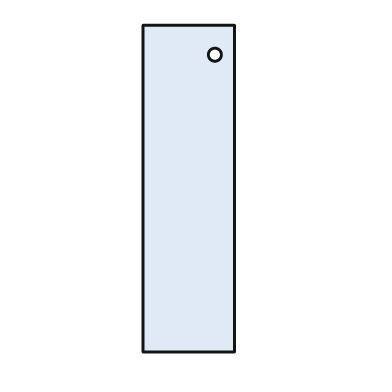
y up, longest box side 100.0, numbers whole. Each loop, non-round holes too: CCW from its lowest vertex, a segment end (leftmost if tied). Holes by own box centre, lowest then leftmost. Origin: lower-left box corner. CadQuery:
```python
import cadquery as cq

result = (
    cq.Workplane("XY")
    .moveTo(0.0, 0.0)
    .lineTo(28.0, 0.0)
    .lineTo(28.0, 100.0)
    .lineTo(0.0, 100.0)
    .close()
    .moveTo(22.0, 91.0)
    .circle(2.0)
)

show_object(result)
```